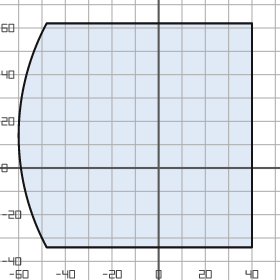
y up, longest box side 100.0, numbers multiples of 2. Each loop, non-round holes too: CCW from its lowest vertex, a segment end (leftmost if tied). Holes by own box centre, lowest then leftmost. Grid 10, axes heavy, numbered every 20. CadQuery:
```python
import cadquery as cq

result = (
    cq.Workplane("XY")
    .moveTo(-48.0, -34.0)
    .lineTo(40.0, -34.0)
    .lineTo(40.0, 62.0)
    .lineTo(-48.0, 62.0)
    .threePointArc((-60.0, 14.0), (-48.0, -34.0))
    .close()
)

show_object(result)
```